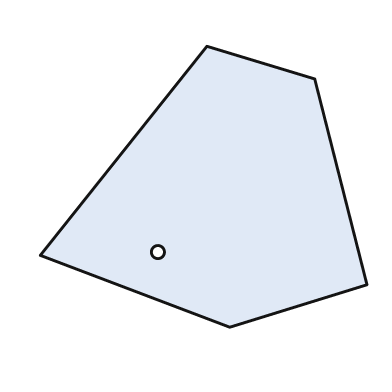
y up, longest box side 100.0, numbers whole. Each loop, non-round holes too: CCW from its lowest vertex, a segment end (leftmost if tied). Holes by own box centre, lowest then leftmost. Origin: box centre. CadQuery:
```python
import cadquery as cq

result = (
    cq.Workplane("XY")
    .moveTo(8.0, -43.0)
    .lineTo(50.0, -30.0)
    .lineTo(34.0, 33.0)
    .lineTo(1.0, 43.0)
    .lineTo(-50.0, -21.0)
    .close()
    .moveTo(-14.0, -20.0)
    .circle(2.0)
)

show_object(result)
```